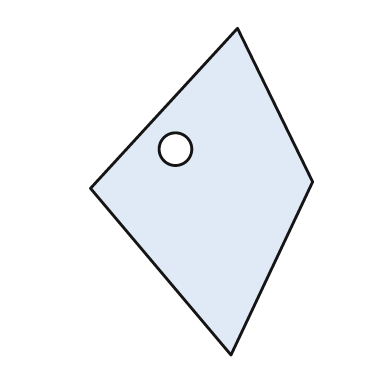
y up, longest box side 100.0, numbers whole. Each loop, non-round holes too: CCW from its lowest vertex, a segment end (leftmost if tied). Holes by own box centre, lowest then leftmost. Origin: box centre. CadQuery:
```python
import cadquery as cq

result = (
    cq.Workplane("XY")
    .moveTo(9.0, -50.0)
    .lineTo(34.0, 3.0)
    .lineTo(11.0, 50.0)
    .lineTo(-34.0, 1.0)
    .close()
    .moveTo(-8.0, 13.0)
    .circle(5.0)
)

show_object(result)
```